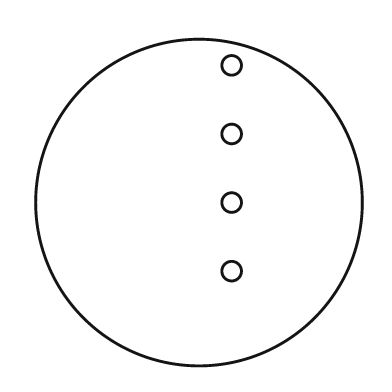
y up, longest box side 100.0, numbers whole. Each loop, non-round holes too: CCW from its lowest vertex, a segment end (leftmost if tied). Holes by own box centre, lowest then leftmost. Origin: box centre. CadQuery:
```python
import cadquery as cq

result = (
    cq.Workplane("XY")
    .moveTo(0.0, 0.0)
    .circle(50.0)
    .moveTo(10.0, -21.0)
    .circle(3.0)
    .moveTo(10.0, 0.0)
    .circle(3.0)
    .moveTo(10.0, 21.0)
    .circle(3.0)
    .moveTo(10.0, 42.0)
    .circle(3.0)
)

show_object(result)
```